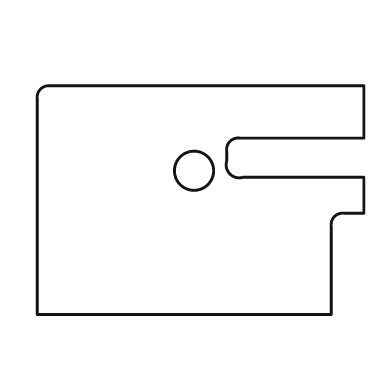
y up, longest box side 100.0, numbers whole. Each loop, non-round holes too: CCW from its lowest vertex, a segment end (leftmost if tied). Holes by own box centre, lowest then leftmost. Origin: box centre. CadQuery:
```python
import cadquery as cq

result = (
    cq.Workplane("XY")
    .moveTo(-50.0, -35.0)
    .lineTo(40.0, -35.0)
    .lineTo(40.0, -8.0)
    .threePointArc((41.0, -5.0), (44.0, -4.0))
    .lineTo(50.0, -4.0)
    .lineTo(50.0, 7.0)
    .lineTo(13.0, 7.0)
    .threePointArc((9.0, 8.0), (8.0, 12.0))
    .lineTo(8.0, 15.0)
    .threePointArc((9.0, 18.0), (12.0, 19.0))
    .lineTo(50.0, 19.0)
    .lineTo(50.0, 35.0)
    .lineTo(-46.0, 35.0)
    .threePointArc((-49.0, 34.0), (-50.0, 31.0))
    .close()
    .moveTo(-2.0, 9.0)
    .circle(6.0)
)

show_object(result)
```